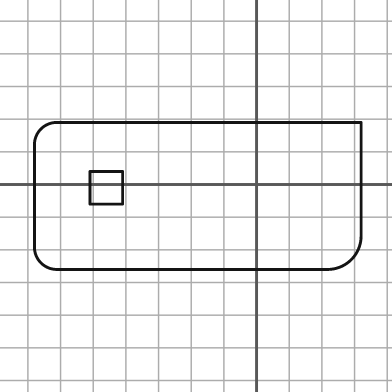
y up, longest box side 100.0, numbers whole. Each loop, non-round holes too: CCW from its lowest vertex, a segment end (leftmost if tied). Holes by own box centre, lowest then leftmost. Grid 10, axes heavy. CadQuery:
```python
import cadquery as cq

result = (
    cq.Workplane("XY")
    .moveTo(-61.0, -26.0)
    .lineTo(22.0, -26.0)
    .threePointArc((29.0, -23.0), (32.0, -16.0))
    .lineTo(32.0, 19.0)
    .lineTo(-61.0, 19.0)
    .threePointArc((-66.0, 17.0), (-68.0, 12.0))
    .lineTo(-68.0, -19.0)
    .threePointArc((-66.0, -24.0), (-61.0, -26.0))
    .close()
    .moveTo(-51.0, -6.0)
    .lineTo(-41.0, -6.0)
    .lineTo(-41.0, 4.0)
    .lineTo(-51.0, 4.0)
    .close()
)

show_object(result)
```